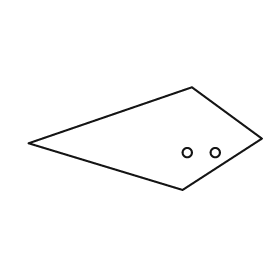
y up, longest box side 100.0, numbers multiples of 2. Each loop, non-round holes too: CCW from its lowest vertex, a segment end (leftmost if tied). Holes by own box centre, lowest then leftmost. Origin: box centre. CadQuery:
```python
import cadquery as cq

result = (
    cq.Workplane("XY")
    .moveTo(16.0, -22.0)
    .lineTo(50.0, 0.0)
    .lineTo(20.0, 22.0)
    .lineTo(-50.0, -2.0)
    .close()
    .moveTo(18.0, -6.0)
    .circle(2.0)
    .moveTo(30.0, -6.0)
    .circle(2.0)
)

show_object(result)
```